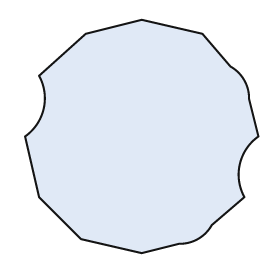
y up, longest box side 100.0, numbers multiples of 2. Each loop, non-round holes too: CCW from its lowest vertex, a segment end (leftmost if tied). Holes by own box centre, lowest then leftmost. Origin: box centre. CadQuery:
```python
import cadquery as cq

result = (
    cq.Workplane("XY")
    .moveTo(0.0, -50.0)
    .lineTo(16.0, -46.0)
    .threePointArc((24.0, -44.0), (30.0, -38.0))
    .lineTo(44.0, -26.0)
    .threePointArc((42.0, -12.0), (50.0, 0.0))
    .lineTo(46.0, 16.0)
    .threePointArc((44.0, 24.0), (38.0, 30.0))
    .lineTo(26.0, 44.0)
    .lineTo(0.0, 50.0)
    .lineTo(-24.0, 44.0)
    .lineTo(-44.0, 26.0)
    .threePointArc((-42.0, 12.0), (-50.0, 0.0))
    .lineTo(-44.0, -26.0)
    .lineTo(-26.0, -44.0)
    .close()
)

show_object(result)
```